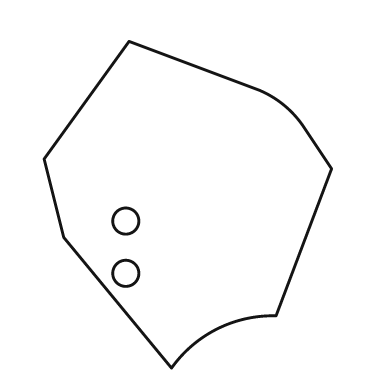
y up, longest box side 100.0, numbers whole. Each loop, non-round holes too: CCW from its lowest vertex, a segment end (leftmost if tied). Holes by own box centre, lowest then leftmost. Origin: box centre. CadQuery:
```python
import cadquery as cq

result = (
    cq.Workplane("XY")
    .moveTo(-5.0, -50.0)
    .threePointArc((9.0, -38.0), (27.0, -34.0))
    .lineTo(44.0, 11.0)
    .lineTo(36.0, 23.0)
    .threePointArc((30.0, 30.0), (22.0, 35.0))
    .lineTo(-18.0, 50.0)
    .lineTo(-44.0, 14.0)
    .lineTo(-38.0, -10.0)
    .close()
    .moveTo(-19.0, -21.0)
    .circle(4.0)
    .moveTo(-19.0, -5.0)
    .circle(4.0)
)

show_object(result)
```